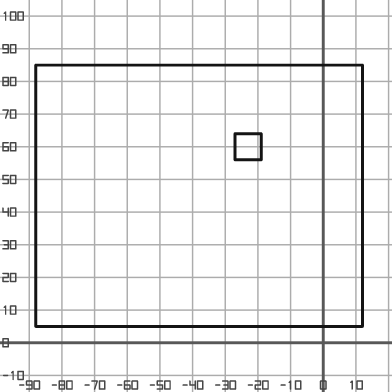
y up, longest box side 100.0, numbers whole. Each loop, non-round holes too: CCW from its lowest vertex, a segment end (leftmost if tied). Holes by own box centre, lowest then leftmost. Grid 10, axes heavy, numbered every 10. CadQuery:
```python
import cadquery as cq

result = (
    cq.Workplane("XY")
    .moveTo(-88.0, 5.0)
    .lineTo(12.0, 5.0)
    .lineTo(12.0, 85.0)
    .lineTo(-88.0, 85.0)
    .close()
    .moveTo(-27.0, 56.0)
    .lineTo(-19.0, 56.0)
    .lineTo(-19.0, 64.0)
    .lineTo(-27.0, 64.0)
    .close()
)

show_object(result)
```